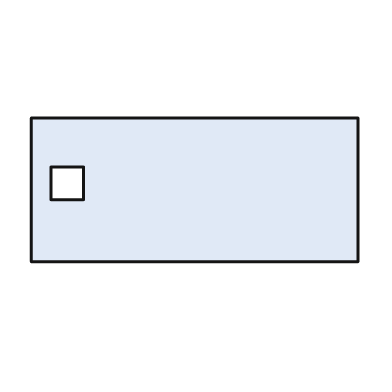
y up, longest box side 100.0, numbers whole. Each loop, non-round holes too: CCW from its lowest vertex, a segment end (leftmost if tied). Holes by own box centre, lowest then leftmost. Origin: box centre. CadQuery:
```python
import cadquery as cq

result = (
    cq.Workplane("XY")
    .moveTo(-50.0, -22.0)
    .lineTo(50.0, -22.0)
    .lineTo(50.0, 22.0)
    .lineTo(-50.0, 22.0)
    .close()
    .moveTo(-44.0, -3.0)
    .lineTo(-34.0, -3.0)
    .lineTo(-34.0, 7.0)
    .lineTo(-44.0, 7.0)
    .close()
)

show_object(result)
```